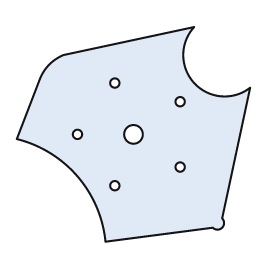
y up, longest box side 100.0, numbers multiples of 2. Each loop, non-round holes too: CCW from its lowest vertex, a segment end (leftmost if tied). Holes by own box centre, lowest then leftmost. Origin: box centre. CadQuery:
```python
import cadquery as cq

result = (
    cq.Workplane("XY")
    .moveTo(-12.0, -46.0)
    .lineTo(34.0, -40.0)
    .threePointArc((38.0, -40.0), (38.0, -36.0))
    .lineTo(50.0, 20.0)
    .threePointArc((26.0, 22.0), (26.0, 46.0))
    .lineTo(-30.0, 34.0)
    .threePointArc((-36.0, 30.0), (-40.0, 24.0))
    .lineTo(-50.0, -2.0)
    .threePointArc((-24.0, -18.0), (-12.0, -46.0))
    .close()
    .moveTo(-8.0, -22.0)
    .circle(2.0)
    .moveTo(20.0, -14.0)
    .circle(2.0)
    .moveTo(-24.0, 0.0)
    .circle(2.0)
    .moveTo(0.0, 0.0)
    .circle(4.0)
    .moveTo(20.0, 14.0)
    .circle(2.0)
    .moveTo(-8.0, 22.0)
    .circle(2.0)
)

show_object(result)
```